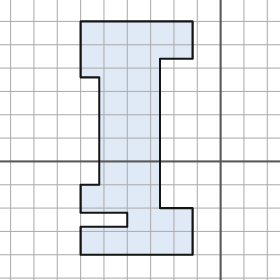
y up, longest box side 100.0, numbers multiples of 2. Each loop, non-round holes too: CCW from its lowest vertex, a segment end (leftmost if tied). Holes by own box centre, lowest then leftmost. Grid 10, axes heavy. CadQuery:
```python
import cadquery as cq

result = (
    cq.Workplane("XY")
    .moveTo(-60.0, -40.0)
    .lineTo(-12.0, -40.0)
    .lineTo(-12.0, -20.0)
    .lineTo(-26.0, -20.0)
    .lineTo(-26.0, 44.0)
    .lineTo(-12.0, 44.0)
    .lineTo(-12.0, 60.0)
    .lineTo(-60.0, 60.0)
    .lineTo(-60.0, 36.0)
    .lineTo(-52.0, 36.0)
    .lineTo(-52.0, -10.0)
    .lineTo(-60.0, -10.0)
    .lineTo(-60.0, -22.0)
    .lineTo(-40.0, -22.0)
    .lineTo(-40.0, -28.0)
    .lineTo(-60.0, -28.0)
    .close()
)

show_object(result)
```